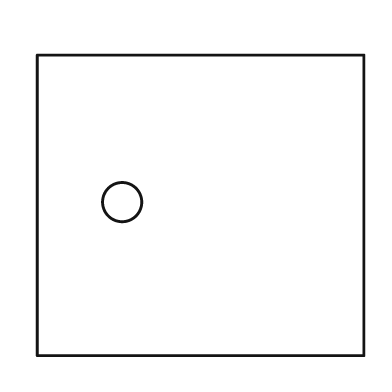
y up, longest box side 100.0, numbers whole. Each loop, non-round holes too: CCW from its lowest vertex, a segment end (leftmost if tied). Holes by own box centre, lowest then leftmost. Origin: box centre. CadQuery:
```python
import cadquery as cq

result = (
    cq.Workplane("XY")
    .moveTo(-50.0, -46.0)
    .lineTo(50.0, -46.0)
    .lineTo(50.0, 46.0)
    .lineTo(-50.0, 46.0)
    .close()
    .moveTo(-24.0, 1.0)
    .circle(6.0)
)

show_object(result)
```